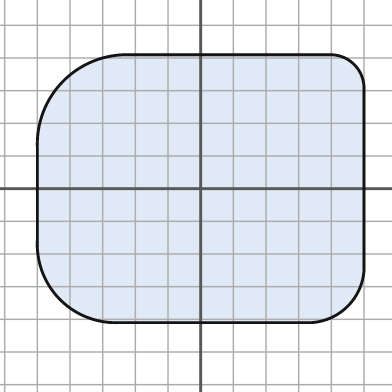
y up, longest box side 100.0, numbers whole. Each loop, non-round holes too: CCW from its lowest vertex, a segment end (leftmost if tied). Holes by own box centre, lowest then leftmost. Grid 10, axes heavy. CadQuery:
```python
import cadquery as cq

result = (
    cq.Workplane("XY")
    .moveTo(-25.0, -41.0)
    .lineTo(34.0, -41.0)
    .threePointArc((45.0, -36.0), (50.0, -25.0))
    .lineTo(50.0, 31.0)
    .threePointArc((47.0, 38.0), (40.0, 41.0))
    .lineTo(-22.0, 41.0)
    .threePointArc((-42.0, 33.0), (-50.0, 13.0))
    .lineTo(-50.0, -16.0)
    .threePointArc((-43.0, -34.0), (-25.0, -41.0))
    .close()
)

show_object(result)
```